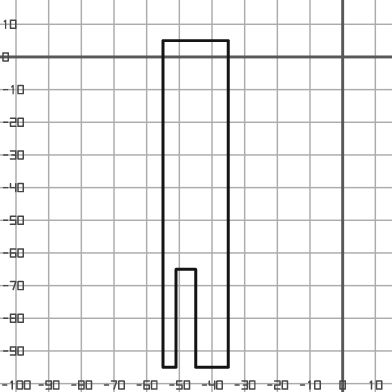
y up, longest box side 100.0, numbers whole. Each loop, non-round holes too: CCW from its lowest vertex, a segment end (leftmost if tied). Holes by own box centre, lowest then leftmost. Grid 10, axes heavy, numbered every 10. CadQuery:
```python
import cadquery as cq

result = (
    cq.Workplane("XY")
    .moveTo(-55.0, -95.0)
    .lineTo(-51.0, -95.0)
    .lineTo(-51.0, -65.0)
    .lineTo(-45.0, -65.0)
    .lineTo(-45.0, -95.0)
    .lineTo(-35.0, -95.0)
    .lineTo(-35.0, 5.0)
    .lineTo(-55.0, 5.0)
    .close()
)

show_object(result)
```